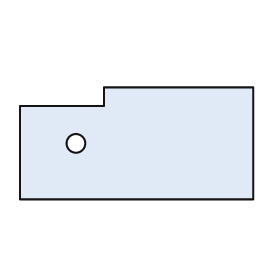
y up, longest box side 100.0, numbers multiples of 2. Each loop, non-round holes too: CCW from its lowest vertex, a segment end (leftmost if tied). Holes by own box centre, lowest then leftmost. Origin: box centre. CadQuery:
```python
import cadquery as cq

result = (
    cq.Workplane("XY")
    .moveTo(-50.0, -24.0)
    .lineTo(50.0, -24.0)
    .lineTo(50.0, 24.0)
    .lineTo(-14.0, 24.0)
    .lineTo(-14.0, 16.0)
    .lineTo(-50.0, 16.0)
    .close()
    .moveTo(-26.0, 0.0)
    .circle(4.0)
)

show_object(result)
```